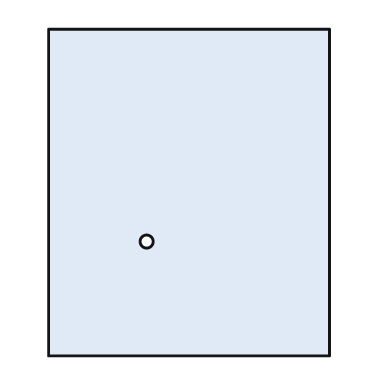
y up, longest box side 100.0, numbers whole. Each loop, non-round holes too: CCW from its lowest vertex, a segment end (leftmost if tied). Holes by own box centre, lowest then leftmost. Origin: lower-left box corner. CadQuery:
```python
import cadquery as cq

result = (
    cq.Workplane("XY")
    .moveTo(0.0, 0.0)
    .lineTo(86.0, 0.0)
    .lineTo(86.0, 100.0)
    .lineTo(0.0, 100.0)
    .close()
    .moveTo(30.0, 35.0)
    .circle(2.0)
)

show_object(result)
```